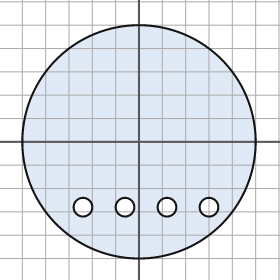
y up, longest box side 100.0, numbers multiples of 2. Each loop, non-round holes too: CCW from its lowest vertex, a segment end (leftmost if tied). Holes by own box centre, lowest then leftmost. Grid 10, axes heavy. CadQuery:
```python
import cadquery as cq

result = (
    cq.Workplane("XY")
    .moveTo(0.0, 0.0)
    .circle(50.0)
    .moveTo(-24.0, -28.0)
    .circle(4.0)
    .moveTo(-6.0, -28.0)
    .circle(4.0)
    .moveTo(12.0, -28.0)
    .circle(4.0)
    .moveTo(30.0, -28.0)
    .circle(4.0)
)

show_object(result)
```